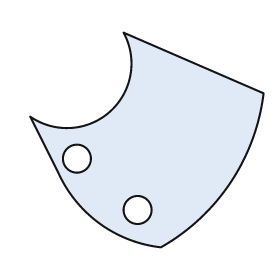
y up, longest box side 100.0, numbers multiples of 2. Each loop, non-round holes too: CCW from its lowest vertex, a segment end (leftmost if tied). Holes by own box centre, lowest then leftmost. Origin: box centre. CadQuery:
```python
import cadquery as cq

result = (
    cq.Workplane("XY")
    .moveTo(6.0, -46.0)
    .threePointArc((36.0, -18.0), (50.0, 20.0))
    .lineTo(-10.0, 46.0)
    .threePointArc((-16.0, 12.0), (-50.0, 10.0))
    .lineTo(-38.0, -14.0)
    .threePointArc((-20.0, -36.0), (6.0, -46.0))
    .close()
    .moveTo(-4.0, -30.0)
    .circle(6.0)
    .moveTo(-30.0, -8.0)
    .circle(6.0)
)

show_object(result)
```